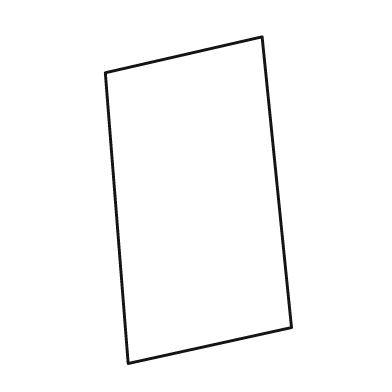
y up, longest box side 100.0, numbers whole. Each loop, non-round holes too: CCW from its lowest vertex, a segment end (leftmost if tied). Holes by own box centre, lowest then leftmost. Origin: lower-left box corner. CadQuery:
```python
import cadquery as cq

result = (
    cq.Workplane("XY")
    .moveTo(7.0, 0.0)
    .lineTo(57.0, 11.0)
    .lineTo(48.0, 100.0)
    .lineTo(0.0, 89.0)
    .close()
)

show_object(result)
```